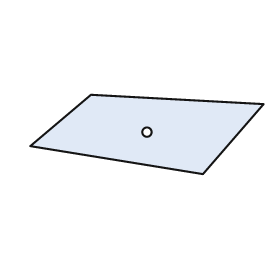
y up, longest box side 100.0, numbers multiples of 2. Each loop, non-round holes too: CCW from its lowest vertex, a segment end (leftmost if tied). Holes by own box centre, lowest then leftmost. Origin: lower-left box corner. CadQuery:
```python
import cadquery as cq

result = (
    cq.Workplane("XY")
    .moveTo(74.0, 0.0)
    .lineTo(100.0, 30.0)
    .lineTo(26.0, 34.0)
    .lineTo(0.0, 12.0)
    .close()
    .moveTo(50.0, 18.0)
    .circle(2.0)
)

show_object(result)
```